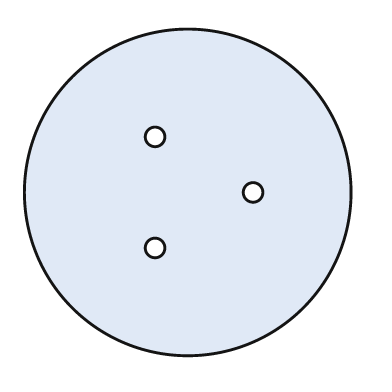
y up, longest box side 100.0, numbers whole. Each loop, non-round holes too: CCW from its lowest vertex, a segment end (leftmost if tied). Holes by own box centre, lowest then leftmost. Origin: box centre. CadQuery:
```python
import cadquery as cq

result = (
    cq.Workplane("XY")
    .moveTo(0.0, 0.0)
    .circle(50.0)
    .moveTo(-10.0, -17.0)
    .circle(3.0)
    .moveTo(20.0, 0.0)
    .circle(3.0)
    .moveTo(-10.0, 17.0)
    .circle(3.0)
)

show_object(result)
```